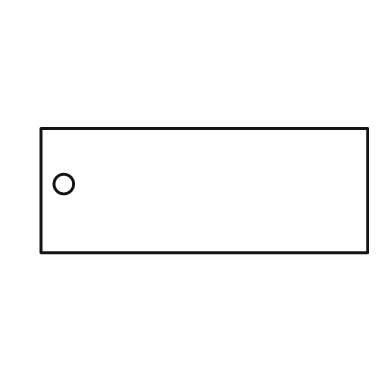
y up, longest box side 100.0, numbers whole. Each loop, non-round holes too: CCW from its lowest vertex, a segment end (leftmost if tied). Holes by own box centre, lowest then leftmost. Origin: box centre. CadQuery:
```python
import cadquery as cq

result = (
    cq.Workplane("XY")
    .moveTo(-50.0, -19.0)
    .lineTo(50.0, -19.0)
    .lineTo(50.0, 19.0)
    .lineTo(-50.0, 19.0)
    .close()
    .moveTo(-43.0, 2.0)
    .circle(3.0)
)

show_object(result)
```